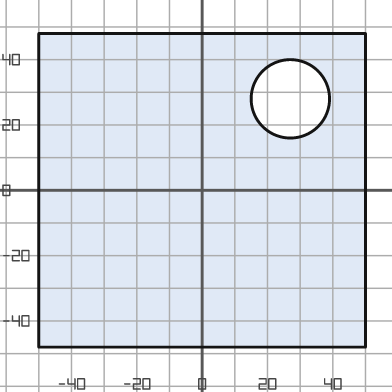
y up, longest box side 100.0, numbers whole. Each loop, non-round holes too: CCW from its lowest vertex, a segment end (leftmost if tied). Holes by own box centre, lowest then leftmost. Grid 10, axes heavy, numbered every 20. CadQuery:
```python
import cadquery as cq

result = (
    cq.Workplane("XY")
    .moveTo(-50.0, -48.0)
    .lineTo(50.0, -48.0)
    .lineTo(50.0, 48.0)
    .lineTo(-50.0, 48.0)
    .close()
    .moveTo(27.0, 28.0)
    .circle(12.0)
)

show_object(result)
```